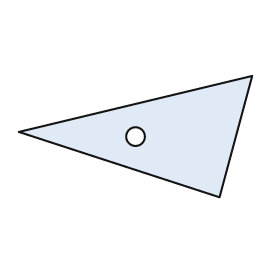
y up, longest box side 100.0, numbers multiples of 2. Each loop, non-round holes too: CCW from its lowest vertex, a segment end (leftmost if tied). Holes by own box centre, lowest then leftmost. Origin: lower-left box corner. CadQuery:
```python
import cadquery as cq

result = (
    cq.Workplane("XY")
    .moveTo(86.0, 0.0)
    .lineTo(100.0, 52.0)
    .lineTo(0.0, 28.0)
    .close()
    .moveTo(50.0, 26.0)
    .circle(4.0)
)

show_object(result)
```